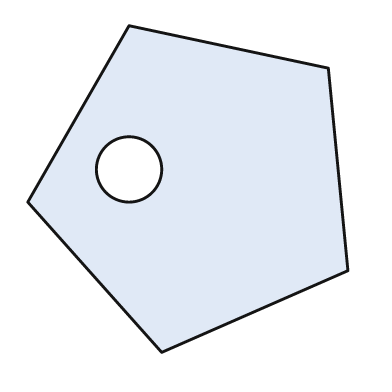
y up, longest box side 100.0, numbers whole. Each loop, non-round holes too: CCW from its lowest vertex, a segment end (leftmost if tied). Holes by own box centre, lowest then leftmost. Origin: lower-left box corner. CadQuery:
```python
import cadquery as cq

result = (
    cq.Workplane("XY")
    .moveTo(41.0, 0.0)
    .lineTo(98.0, 25.0)
    .lineTo(92.0, 87.0)
    .lineTo(31.0, 100.0)
    .lineTo(0.0, 46.0)
    .close()
    .moveTo(31.0, 56.0)
    .circle(10.0)
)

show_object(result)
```